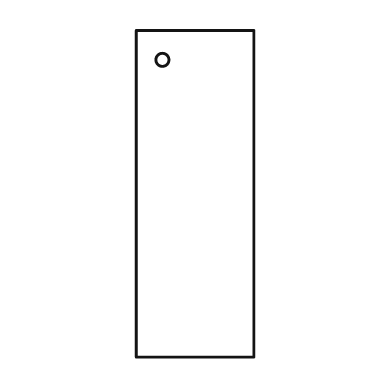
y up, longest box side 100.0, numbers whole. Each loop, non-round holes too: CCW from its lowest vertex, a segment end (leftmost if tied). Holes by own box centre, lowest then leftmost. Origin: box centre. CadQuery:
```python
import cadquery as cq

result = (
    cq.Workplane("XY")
    .moveTo(-18.0, -50.0)
    .lineTo(18.0, -50.0)
    .lineTo(18.0, 50.0)
    .lineTo(-18.0, 50.0)
    .close()
    .moveTo(-10.0, 41.0)
    .circle(2.0)
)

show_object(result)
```